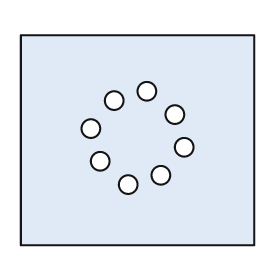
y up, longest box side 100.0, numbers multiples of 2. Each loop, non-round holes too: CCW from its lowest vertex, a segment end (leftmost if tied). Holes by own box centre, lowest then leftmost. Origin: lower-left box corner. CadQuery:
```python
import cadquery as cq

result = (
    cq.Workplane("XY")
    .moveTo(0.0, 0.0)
    .lineTo(100.0, 0.0)
    .lineTo(100.0, 90.0)
    .lineTo(0.0, 90.0)
    .close()
    .moveTo(46.0, 26.0)
    .circle(4.0)
    .moveTo(60.0, 30.0)
    .circle(4.0)
    .moveTo(34.0, 36.0)
    .circle(4.0)
    .moveTo(70.0, 42.0)
    .circle(4.0)
    .moveTo(30.0, 50.0)
    .circle(4.0)
    .moveTo(66.0, 56.0)
    .circle(4.0)
    .moveTo(40.0, 62.0)
    .circle(4.0)
    .moveTo(54.0, 66.0)
    .circle(4.0)
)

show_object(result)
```